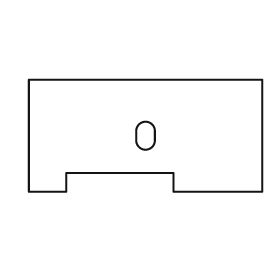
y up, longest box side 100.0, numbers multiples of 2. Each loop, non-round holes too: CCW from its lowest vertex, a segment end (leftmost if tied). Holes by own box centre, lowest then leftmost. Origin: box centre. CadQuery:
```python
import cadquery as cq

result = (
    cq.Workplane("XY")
    .moveTo(-50.0, -24.0)
    .lineTo(-34.0, -24.0)
    .lineTo(-34.0, -16.0)
    .lineTo(12.0, -16.0)
    .lineTo(12.0, -24.0)
    .lineTo(50.0, -24.0)
    .lineTo(50.0, 24.0)
    .lineTo(-50.0, 24.0)
    .close()
    .moveTo(-4.0, -2.0)
    .threePointArc((0.0, -6.0), (4.0, -2.0))
    .lineTo(4.0, 2.0)
    .threePointArc((0.0, 6.0), (-4.0, 2.0))
    .close()
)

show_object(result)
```